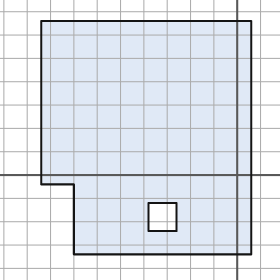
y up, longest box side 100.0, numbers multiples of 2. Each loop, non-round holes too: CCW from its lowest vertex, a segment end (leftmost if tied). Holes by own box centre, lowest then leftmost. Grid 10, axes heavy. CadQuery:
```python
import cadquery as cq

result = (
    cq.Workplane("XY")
    .moveTo(-70.0, -34.0)
    .lineTo(6.0, -34.0)
    .lineTo(6.0, 66.0)
    .lineTo(-84.0, 66.0)
    .lineTo(-84.0, -4.0)
    .lineTo(-70.0, -4.0)
    .close()
    .moveTo(-38.0, -24.0)
    .lineTo(-26.0, -24.0)
    .lineTo(-26.0, -12.0)
    .lineTo(-38.0, -12.0)
    .close()
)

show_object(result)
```